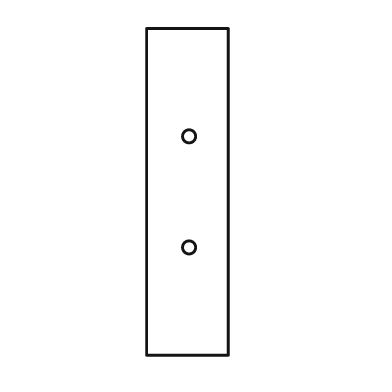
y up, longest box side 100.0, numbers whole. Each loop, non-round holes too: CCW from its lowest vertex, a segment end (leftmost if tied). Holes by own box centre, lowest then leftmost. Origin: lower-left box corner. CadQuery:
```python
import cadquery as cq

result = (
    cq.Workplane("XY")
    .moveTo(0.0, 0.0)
    .lineTo(25.0, 0.0)
    .lineTo(25.0, 100.0)
    .lineTo(0.0, 100.0)
    .close()
    .moveTo(13.0, 33.0)
    .circle(2.0)
    .moveTo(13.0, 67.0)
    .circle(2.0)
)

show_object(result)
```